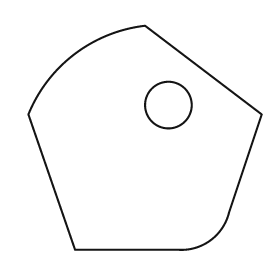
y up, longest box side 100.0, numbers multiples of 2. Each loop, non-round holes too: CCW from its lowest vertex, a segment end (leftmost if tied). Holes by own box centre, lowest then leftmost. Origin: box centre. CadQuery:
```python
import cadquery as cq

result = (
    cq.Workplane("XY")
    .moveTo(-30.0, -48.0)
    .lineTo(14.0, -48.0)
    .threePointArc((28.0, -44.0), (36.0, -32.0))
    .lineTo(50.0, 10.0)
    .lineTo(0.0, 48.0)
    .threePointArc((-30.0, 36.0), (-50.0, 10.0))
    .close()
    .moveTo(10.0, 14.0)
    .circle(10.0)
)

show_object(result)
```